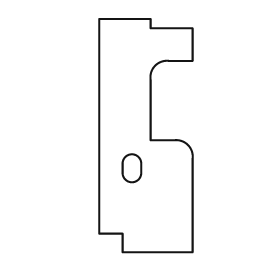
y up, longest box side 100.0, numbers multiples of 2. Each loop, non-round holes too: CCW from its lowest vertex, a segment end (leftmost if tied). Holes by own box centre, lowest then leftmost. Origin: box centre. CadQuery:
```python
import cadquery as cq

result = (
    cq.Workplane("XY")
    .moveTo(-10.0, -50.0)
    .lineTo(20.0, -50.0)
    .lineTo(20.0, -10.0)
    .threePointArc((18.0, -4.0), (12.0, -2.0))
    .lineTo(2.0, -2.0)
    .lineTo(2.0, 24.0)
    .threePointArc((4.0, 30.0), (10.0, 32.0))
    .lineTo(20.0, 32.0)
    .lineTo(20.0, 46.0)
    .lineTo(2.0, 46.0)
    .lineTo(2.0, 50.0)
    .lineTo(-20.0, 50.0)
    .lineTo(-20.0, -42.0)
    .lineTo(-10.0, -42.0)
    .close()
    .moveTo(-10.0, -16.0)
    .threePointArc((-6.0, -20.0), (-2.0, -16.0))
    .lineTo(-2.0, -12.0)
    .threePointArc((-6.0, -8.0), (-10.0, -12.0))
    .close()
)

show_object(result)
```